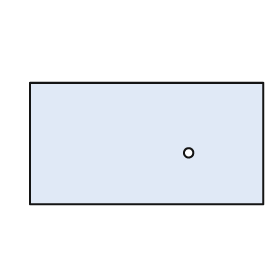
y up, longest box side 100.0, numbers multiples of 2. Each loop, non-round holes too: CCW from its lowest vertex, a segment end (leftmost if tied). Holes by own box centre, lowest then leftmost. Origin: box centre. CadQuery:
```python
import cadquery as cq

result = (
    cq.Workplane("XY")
    .moveTo(-50.0, -26.0)
    .lineTo(50.0, -26.0)
    .lineTo(50.0, 26.0)
    .lineTo(-50.0, 26.0)
    .close()
    .moveTo(18.0, -4.0)
    .circle(2.0)
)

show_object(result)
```